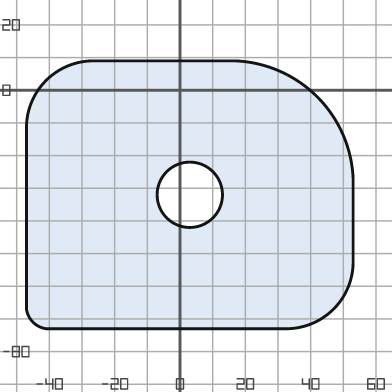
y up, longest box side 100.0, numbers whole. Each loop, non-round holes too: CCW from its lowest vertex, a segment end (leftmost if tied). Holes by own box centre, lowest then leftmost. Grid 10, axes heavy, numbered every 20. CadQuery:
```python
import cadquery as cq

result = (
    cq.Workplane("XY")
    .moveTo(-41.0, -73.0)
    .lineTo(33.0, -73.0)
    .threePointArc((47.0, -67.0), (53.0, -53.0))
    .lineTo(53.0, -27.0)
    .threePointArc((42.0, -2.0), (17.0, 9.0))
    .lineTo(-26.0, 9.0)
    .threePointArc((-41.0, 3.0), (-47.0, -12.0))
    .lineTo(-47.0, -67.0)
    .threePointArc((-45.0, -71.0), (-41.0, -73.0))
    .close()
    .moveTo(3.0, -32.0)
    .circle(10.0)
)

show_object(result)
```